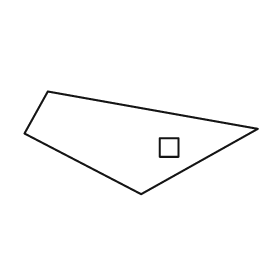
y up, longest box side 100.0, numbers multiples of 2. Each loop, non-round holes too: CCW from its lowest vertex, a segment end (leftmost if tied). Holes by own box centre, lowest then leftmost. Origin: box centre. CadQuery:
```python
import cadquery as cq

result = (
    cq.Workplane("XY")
    .moveTo(0.0, -22.0)
    .lineTo(50.0, 6.0)
    .lineTo(-40.0, 22.0)
    .lineTo(-50.0, 4.0)
    .close()
    .moveTo(8.0, -6.0)
    .lineTo(16.0, -6.0)
    .lineTo(16.0, 2.0)
    .lineTo(8.0, 2.0)
    .close()
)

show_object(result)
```